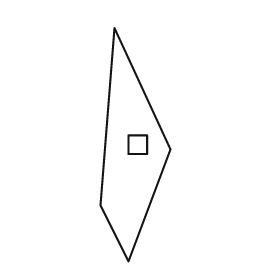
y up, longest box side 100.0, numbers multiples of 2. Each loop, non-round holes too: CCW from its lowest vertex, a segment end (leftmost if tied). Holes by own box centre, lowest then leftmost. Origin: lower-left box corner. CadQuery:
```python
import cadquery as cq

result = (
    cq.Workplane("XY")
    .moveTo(12.0, 0.0)
    .lineTo(30.0, 48.0)
    .lineTo(6.0, 100.0)
    .lineTo(0.0, 24.0)
    .close()
    .moveTo(12.0, 46.0)
    .lineTo(20.0, 46.0)
    .lineTo(20.0, 54.0)
    .lineTo(12.0, 54.0)
    .close()
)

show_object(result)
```